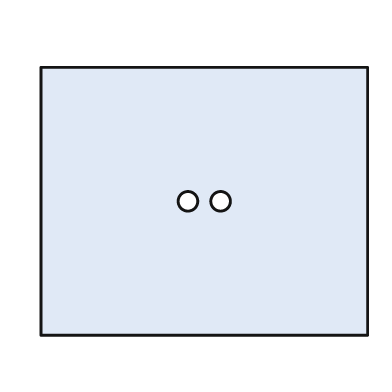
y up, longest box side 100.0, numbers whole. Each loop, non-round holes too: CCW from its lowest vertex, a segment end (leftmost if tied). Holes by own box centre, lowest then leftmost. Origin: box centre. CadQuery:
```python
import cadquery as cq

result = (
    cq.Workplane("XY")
    .moveTo(-50.0, -41.0)
    .lineTo(50.0, -41.0)
    .lineTo(50.0, 41.0)
    .lineTo(-50.0, 41.0)
    .close()
    .moveTo(-5.0, 0.0)
    .circle(3.0)
    .moveTo(5.0, 0.0)
    .circle(3.0)
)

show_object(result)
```